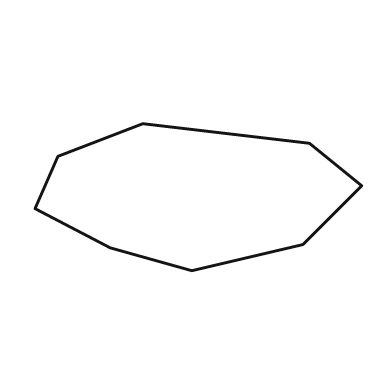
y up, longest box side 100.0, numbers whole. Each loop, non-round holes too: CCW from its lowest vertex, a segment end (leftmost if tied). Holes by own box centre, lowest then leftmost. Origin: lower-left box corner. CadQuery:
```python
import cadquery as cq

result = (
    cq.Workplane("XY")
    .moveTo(48.0, 0.0)
    .lineTo(82.0, 8.0)
    .lineTo(100.0, 26.0)
    .lineTo(84.0, 39.0)
    .lineTo(33.0, 45.0)
    .lineTo(7.0, 35.0)
    .lineTo(0.0, 19.0)
    .lineTo(23.0, 7.0)
    .close()
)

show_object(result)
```